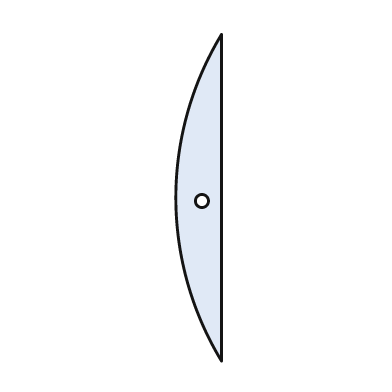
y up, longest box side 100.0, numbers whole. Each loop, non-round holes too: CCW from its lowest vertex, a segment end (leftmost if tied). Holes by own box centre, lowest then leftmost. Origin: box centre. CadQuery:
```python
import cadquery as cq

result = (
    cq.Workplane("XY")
    .moveTo(7.0, -50.0)
    .lineTo(7.0, 50.0)
    .threePointArc((-7.0, 0.0), (7.0, -50.0))
    .close()
    .moveTo(1.0, -1.0)
    .circle(2.0)
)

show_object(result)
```